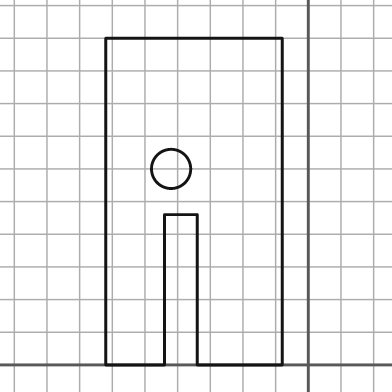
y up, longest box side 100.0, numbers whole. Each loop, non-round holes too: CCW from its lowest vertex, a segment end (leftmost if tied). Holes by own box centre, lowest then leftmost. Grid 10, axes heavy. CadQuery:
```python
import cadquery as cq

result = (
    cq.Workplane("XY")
    .moveTo(-62.0, 0.0)
    .lineTo(-44.0, 0.0)
    .lineTo(-44.0, 46.0)
    .lineTo(-34.0, 46.0)
    .lineTo(-34.0, 0.0)
    .lineTo(-8.0, 0.0)
    .lineTo(-8.0, 100.0)
    .lineTo(-62.0, 100.0)
    .close()
    .moveTo(-42.0, 60.0)
    .circle(6.0)
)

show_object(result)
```